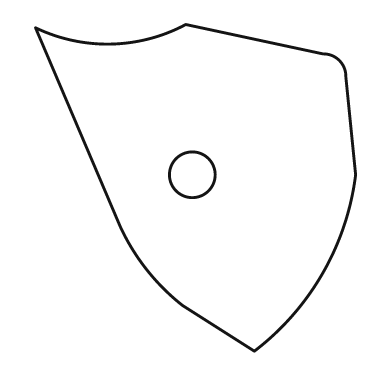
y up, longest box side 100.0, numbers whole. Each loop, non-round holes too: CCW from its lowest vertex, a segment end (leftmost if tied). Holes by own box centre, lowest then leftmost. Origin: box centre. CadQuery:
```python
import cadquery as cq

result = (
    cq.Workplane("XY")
    .moveTo(18.0, -50.0)
    .threePointArc((39.0, -26.0), (49.0, 4.0))
    .lineTo(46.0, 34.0)
    .threePointArc((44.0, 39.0), (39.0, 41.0))
    .lineTo(-3.0, 50.0)
    .threePointArc((-26.0, 44.0), (-49.0, 49.0))
    .lineTo(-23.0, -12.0)
    .threePointArc((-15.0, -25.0), (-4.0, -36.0))
    .close()
    .moveTo(-1.0, 4.0)
    .circle(7.0)
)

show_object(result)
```